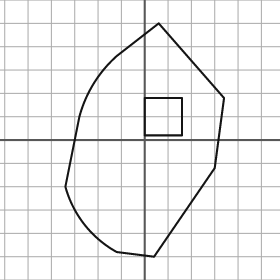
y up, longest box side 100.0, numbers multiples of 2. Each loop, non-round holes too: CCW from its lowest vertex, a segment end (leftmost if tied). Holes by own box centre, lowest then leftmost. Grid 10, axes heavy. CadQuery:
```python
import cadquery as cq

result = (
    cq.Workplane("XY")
    .moveTo(4.0, -50.0)
    .lineTo(30.0, -12.0)
    .lineTo(34.0, 18.0)
    .lineTo(6.0, 50.0)
    .lineTo(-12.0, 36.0)
    .threePointArc((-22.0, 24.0), (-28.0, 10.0))
    .lineTo(-34.0, -20.0)
    .threePointArc((-26.0, -36.0), (-12.0, -48.0))
    .close()
    .moveTo(0.0, 2.0)
    .lineTo(16.0, 2.0)
    .lineTo(16.0, 18.0)
    .lineTo(0.0, 18.0)
    .close()
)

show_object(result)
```